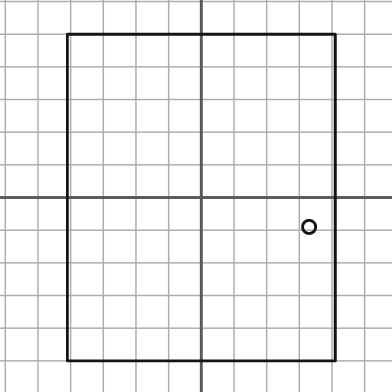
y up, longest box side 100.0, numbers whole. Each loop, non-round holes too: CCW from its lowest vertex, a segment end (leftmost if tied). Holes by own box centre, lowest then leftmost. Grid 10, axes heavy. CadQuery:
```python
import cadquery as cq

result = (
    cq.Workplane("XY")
    .moveTo(-41.0, -50.0)
    .lineTo(41.0, -50.0)
    .lineTo(41.0, 50.0)
    .lineTo(-41.0, 50.0)
    .close()
    .moveTo(33.0, -9.0)
    .circle(2.0)
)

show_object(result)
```